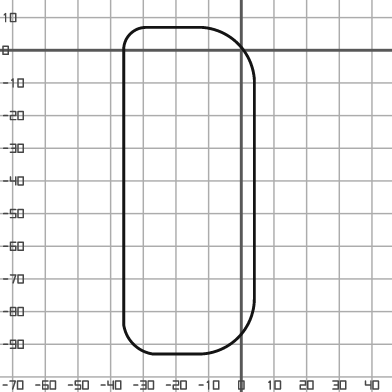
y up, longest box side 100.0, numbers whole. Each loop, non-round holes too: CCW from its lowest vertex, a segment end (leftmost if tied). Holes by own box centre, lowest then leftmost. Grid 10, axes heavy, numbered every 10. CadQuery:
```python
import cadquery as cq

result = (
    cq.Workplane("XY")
    .moveTo(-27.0, -93.0)
    .lineTo(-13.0, -93.0)
    .threePointArc((-1.0, -88.0), (4.0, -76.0))
    .lineTo(4.0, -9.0)
    .threePointArc((-1.0, 2.0), (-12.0, 7.0))
    .lineTo(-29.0, 7.0)
    .threePointArc((-34.0, 5.0), (-36.0, 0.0))
    .lineTo(-36.0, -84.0)
    .threePointArc((-33.0, -90.0), (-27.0, -93.0))
    .close()
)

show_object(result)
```